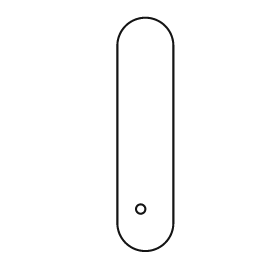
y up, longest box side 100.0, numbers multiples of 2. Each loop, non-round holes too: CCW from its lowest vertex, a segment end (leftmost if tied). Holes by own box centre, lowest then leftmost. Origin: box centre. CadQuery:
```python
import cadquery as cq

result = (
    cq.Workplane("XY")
    .moveTo(-12.0, -38.0)
    .threePointArc((0.0, -50.0), (12.0, -38.0))
    .lineTo(12.0, 38.0)
    .threePointArc((0.0, 50.0), (-12.0, 38.0))
    .close()
    .moveTo(-2.0, -32.0)
    .circle(2.0)
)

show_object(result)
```